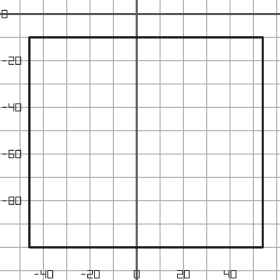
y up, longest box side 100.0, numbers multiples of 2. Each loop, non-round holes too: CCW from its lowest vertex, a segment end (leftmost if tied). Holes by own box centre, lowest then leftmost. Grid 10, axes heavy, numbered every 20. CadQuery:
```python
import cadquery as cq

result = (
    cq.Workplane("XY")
    .moveTo(-46.0, -100.0)
    .lineTo(54.0, -100.0)
    .lineTo(54.0, -10.0)
    .lineTo(-46.0, -10.0)
    .close()
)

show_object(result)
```